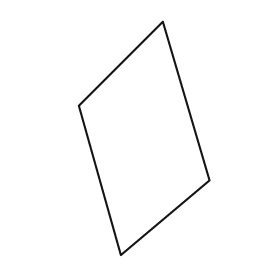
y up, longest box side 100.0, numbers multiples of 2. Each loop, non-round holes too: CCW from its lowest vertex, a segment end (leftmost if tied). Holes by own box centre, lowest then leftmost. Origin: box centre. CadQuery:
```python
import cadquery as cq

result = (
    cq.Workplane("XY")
    .moveTo(-10.0, -50.0)
    .lineTo(28.0, -18.0)
    .lineTo(8.0, 50.0)
    .lineTo(-28.0, 14.0)
    .close()
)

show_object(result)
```